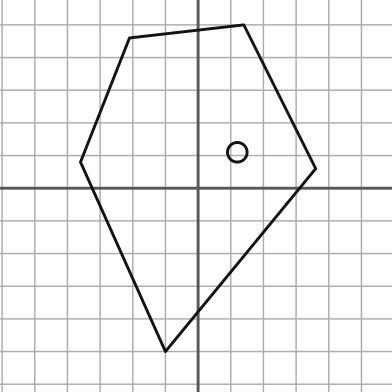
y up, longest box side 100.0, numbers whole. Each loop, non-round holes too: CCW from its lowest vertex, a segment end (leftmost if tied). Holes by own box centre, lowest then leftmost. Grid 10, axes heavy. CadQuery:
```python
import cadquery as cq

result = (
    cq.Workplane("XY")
    .moveTo(-10.0, -50.0)
    .lineTo(36.0, 6.0)
    .lineTo(14.0, 50.0)
    .lineTo(-21.0, 46.0)
    .lineTo(-36.0, 8.0)
    .close()
    .moveTo(12.0, 11.0)
    .circle(3.0)
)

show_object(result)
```